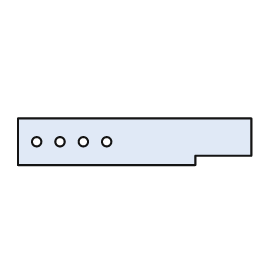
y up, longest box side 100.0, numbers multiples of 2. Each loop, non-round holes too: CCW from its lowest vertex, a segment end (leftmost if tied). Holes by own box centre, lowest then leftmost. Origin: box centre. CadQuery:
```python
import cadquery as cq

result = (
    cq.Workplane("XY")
    .moveTo(-50.0, -10.0)
    .lineTo(26.0, -10.0)
    .lineTo(26.0, -6.0)
    .lineTo(50.0, -6.0)
    .lineTo(50.0, 10.0)
    .lineTo(-50.0, 10.0)
    .close()
    .moveTo(-42.0, 0.0)
    .circle(2.0)
    .moveTo(-32.0, 0.0)
    .circle(2.0)
    .moveTo(-22.0, 0.0)
    .circle(2.0)
    .moveTo(-12.0, 0.0)
    .circle(2.0)
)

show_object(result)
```